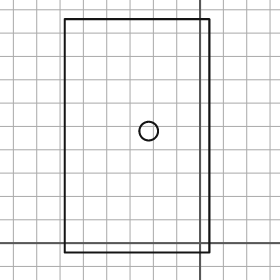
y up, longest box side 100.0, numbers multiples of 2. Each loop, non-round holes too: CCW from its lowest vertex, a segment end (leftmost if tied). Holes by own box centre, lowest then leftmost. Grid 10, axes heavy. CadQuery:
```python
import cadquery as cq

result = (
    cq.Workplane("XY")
    .moveTo(-58.0, -4.0)
    .lineTo(4.0, -4.0)
    .lineTo(4.0, 96.0)
    .lineTo(-58.0, 96.0)
    .close()
    .moveTo(-22.0, 48.0)
    .circle(4.0)
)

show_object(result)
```